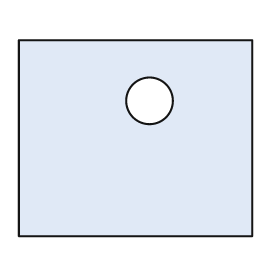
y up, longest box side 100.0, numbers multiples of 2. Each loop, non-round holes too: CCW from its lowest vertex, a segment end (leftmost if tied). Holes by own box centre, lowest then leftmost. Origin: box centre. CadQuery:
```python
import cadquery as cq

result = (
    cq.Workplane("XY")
    .moveTo(-50.0, -42.0)
    .lineTo(50.0, -42.0)
    .lineTo(50.0, 42.0)
    .lineTo(-50.0, 42.0)
    .close()
    .moveTo(6.0, 16.0)
    .circle(10.0)
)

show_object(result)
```